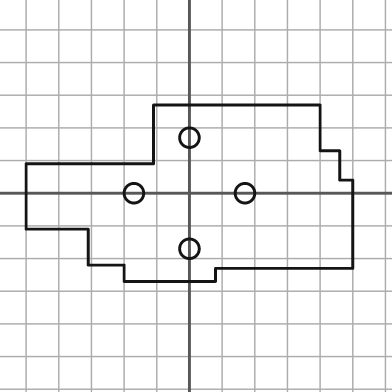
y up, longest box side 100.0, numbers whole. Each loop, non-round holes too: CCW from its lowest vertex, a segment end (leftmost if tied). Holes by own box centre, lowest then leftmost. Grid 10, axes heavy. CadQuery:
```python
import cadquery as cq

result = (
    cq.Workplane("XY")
    .moveTo(-20.0, -27.0)
    .lineTo(8.0, -27.0)
    .lineTo(8.0, -23.0)
    .lineTo(50.0, -23.0)
    .lineTo(50.0, 4.0)
    .lineTo(46.0, 4.0)
    .lineTo(46.0, 13.0)
    .lineTo(40.0, 13.0)
    .lineTo(40.0, 27.0)
    .lineTo(-11.0, 27.0)
    .lineTo(-11.0, 9.0)
    .lineTo(-50.0, 9.0)
    .lineTo(-50.0, -11.0)
    .lineTo(-31.0, -11.0)
    .lineTo(-31.0, -22.0)
    .lineTo(-20.0, -22.0)
    .close()
    .moveTo(0.0, -17.0)
    .circle(3.0)
    .moveTo(-17.0, 0.0)
    .circle(3.0)
    .moveTo(17.0, 0.0)
    .circle(3.0)
    .moveTo(0.0, 17.0)
    .circle(3.0)
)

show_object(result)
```